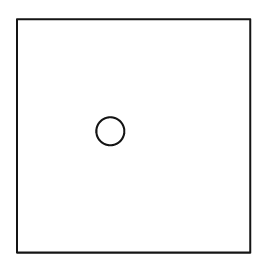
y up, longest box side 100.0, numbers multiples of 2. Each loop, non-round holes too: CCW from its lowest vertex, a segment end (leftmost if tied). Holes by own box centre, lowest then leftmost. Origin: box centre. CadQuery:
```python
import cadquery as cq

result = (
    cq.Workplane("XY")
    .moveTo(-50.0, -50.0)
    .lineTo(50.0, -50.0)
    .lineTo(50.0, 50.0)
    .lineTo(-50.0, 50.0)
    .close()
    .moveTo(-10.0, 2.0)
    .circle(6.0)
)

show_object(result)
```